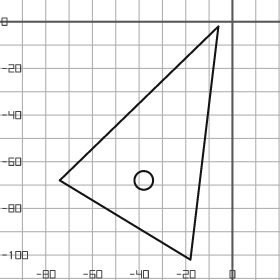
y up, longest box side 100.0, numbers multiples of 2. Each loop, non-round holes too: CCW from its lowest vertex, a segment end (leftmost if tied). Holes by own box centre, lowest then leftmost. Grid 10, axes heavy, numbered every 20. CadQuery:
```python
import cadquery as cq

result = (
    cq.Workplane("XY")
    .moveTo(-18.0, -102.0)
    .lineTo(-6.0, -2.0)
    .lineTo(-74.0, -68.0)
    .close()
    .moveTo(-38.0, -68.0)
    .circle(4.0)
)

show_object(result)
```